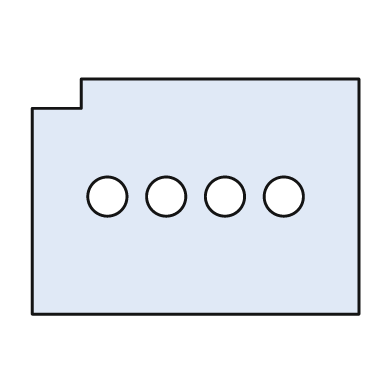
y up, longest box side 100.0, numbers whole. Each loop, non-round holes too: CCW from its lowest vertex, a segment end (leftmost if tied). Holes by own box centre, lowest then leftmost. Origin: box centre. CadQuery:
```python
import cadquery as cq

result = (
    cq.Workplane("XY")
    .moveTo(-50.0, -36.0)
    .lineTo(50.0, -36.0)
    .lineTo(50.0, 36.0)
    .lineTo(-35.0, 36.0)
    .lineTo(-35.0, 27.0)
    .lineTo(-50.0, 27.0)
    .close()
    .moveTo(-27.0, 0.0)
    .circle(6.0)
    .moveTo(-9.0, 0.0)
    .circle(6.0)
    .moveTo(9.0, 0.0)
    .circle(6.0)
    .moveTo(27.0, 0.0)
    .circle(6.0)
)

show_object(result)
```